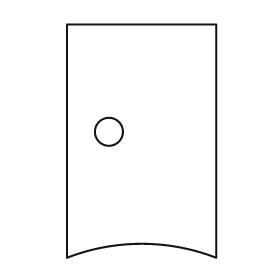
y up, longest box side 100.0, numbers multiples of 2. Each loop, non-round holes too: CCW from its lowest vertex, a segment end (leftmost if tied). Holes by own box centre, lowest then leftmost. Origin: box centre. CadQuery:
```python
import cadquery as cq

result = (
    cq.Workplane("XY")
    .moveTo(-32.0, -50.0)
    .threePointArc((0.0, -44.0), (32.0, -50.0))
    .lineTo(32.0, 50.0)
    .lineTo(-32.0, 50.0)
    .close()
    .moveTo(-14.0, 4.0)
    .circle(6.0)
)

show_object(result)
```